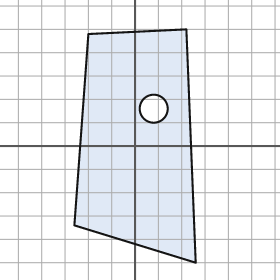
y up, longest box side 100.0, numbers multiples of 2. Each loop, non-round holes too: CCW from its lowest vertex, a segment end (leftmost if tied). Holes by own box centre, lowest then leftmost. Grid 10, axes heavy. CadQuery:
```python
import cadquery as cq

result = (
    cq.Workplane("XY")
    .moveTo(26.0, -50.0)
    .lineTo(22.0, 50.0)
    .lineTo(-20.0, 48.0)
    .lineTo(-26.0, -34.0)
    .close()
    .moveTo(8.0, 16.0)
    .circle(6.0)
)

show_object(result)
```